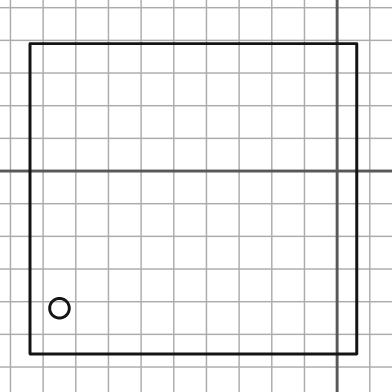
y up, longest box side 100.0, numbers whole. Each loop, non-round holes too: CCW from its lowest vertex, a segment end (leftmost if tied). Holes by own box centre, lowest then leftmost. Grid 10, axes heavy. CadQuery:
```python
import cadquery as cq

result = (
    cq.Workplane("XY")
    .moveTo(-94.0, -56.0)
    .lineTo(6.0, -56.0)
    .lineTo(6.0, 39.0)
    .lineTo(-94.0, 39.0)
    .close()
    .moveTo(-85.0, -42.0)
    .circle(3.0)
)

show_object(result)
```